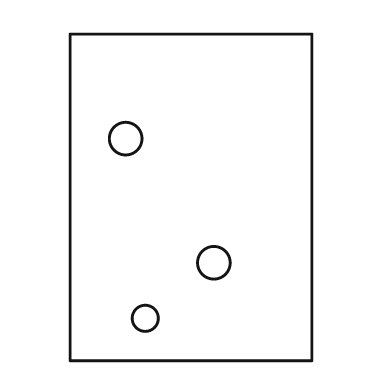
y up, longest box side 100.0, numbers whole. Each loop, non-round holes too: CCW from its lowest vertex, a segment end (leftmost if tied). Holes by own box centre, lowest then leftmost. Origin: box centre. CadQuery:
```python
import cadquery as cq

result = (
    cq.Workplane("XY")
    .moveTo(-37.0, -50.0)
    .lineTo(37.0, -50.0)
    .lineTo(37.0, 50.0)
    .lineTo(-37.0, 50.0)
    .close()
    .moveTo(-14.0, -37.0)
    .circle(4.0)
    .moveTo(7.0, -20.0)
    .circle(5.0)
    .moveTo(-20.0, 18.0)
    .circle(5.0)
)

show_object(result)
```